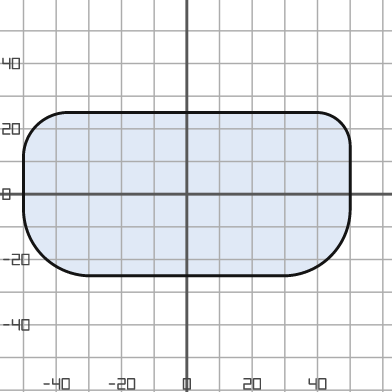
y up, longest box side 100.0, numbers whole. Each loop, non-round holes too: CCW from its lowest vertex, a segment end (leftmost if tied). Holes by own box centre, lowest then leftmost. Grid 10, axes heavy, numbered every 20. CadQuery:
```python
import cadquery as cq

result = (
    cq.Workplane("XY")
    .moveTo(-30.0, -25.0)
    .lineTo(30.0, -25.0)
    .threePointArc((44.0, -19.0), (50.0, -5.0))
    .lineTo(50.0, 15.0)
    .threePointArc((47.0, 22.0), (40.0, 25.0))
    .lineTo(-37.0, 25.0)
    .threePointArc((-46.0, 21.0), (-50.0, 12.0))
    .lineTo(-50.0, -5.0)
    .threePointArc((-44.0, -19.0), (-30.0, -25.0))
    .close()
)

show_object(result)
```